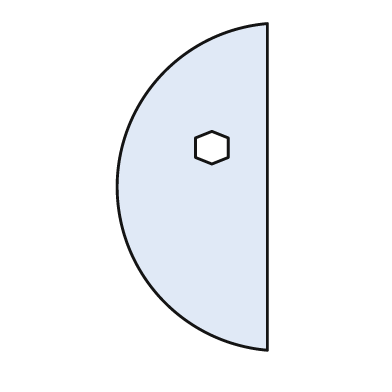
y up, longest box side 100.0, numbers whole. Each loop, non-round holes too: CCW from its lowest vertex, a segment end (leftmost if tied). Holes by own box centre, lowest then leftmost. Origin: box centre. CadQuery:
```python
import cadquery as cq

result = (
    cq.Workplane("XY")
    .moveTo(23.0, -50.0)
    .lineTo(23.0, 50.0)
    .threePointArc((-23.0, 0.0), (23.0, -50.0))
    .close()
    .moveTo(6.0, 7.0)
    .lineTo(11.0, 9.0)
    .lineTo(11.0, 15.0)
    .lineTo(6.0, 17.0)
    .lineTo(1.0, 15.0)
    .lineTo(1.0, 9.0)
    .close()
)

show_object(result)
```